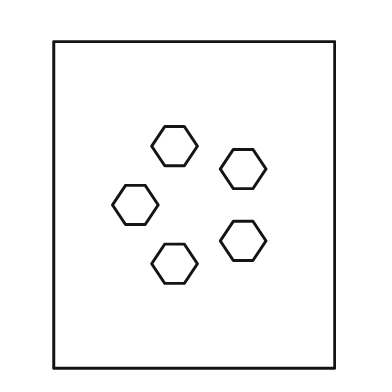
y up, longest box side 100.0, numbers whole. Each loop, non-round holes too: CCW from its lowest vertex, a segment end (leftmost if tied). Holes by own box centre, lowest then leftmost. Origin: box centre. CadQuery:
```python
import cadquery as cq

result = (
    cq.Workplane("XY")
    .moveTo(-43.0, -50.0)
    .lineTo(43.0, -50.0)
    .lineTo(43.0, 50.0)
    .lineTo(-43.0, 50.0)
    .close()
    .moveTo(-9.0, -24.0)
    .lineTo(-3.0, -24.0)
    .lineTo(1.0, -18.0)
    .lineTo(-3.0, -12.0)
    .lineTo(-9.0, -12.0)
    .lineTo(-13.0, -18.0)
    .close()
    .moveTo(12.0, -17.0)
    .lineTo(18.0, -17.0)
    .lineTo(22.0, -11.0)
    .lineTo(18.0, -5.0)
    .lineTo(12.0, -5.0)
    .lineTo(8.0, -11.0)
    .close()
    .moveTo(-21.0, -6.0)
    .lineTo(-15.0, -6.0)
    .lineTo(-11.0, 0.0)
    .lineTo(-15.0, 6.0)
    .lineTo(-21.0, 6.0)
    .lineTo(-25.0, 0.0)
    .close()
    .moveTo(12.0, 5.0)
    .lineTo(18.0, 5.0)
    .lineTo(22.0, 11.0)
    .lineTo(18.0, 17.0)
    .lineTo(12.0, 17.0)
    .lineTo(8.0, 11.0)
    .close()
    .moveTo(-9.0, 12.0)
    .lineTo(-3.0, 12.0)
    .lineTo(1.0, 18.0)
    .lineTo(-3.0, 24.0)
    .lineTo(-9.0, 24.0)
    .lineTo(-13.0, 18.0)
    .close()
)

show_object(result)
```